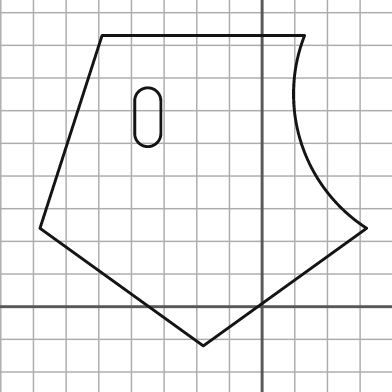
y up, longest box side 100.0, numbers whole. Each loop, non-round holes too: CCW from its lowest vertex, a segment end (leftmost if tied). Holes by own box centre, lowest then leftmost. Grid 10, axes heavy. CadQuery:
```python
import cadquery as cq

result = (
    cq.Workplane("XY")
    .moveTo(-18.0, -12.0)
    .lineTo(32.0, 24.0)
    .threePointArc((12.0, 50.0), (13.0, 83.0))
    .lineTo(-49.0, 83.0)
    .lineTo(-68.0, 24.0)
    .close()
    .moveTo(-39.0, 53.0)
    .threePointArc((-35.0, 49.0), (-31.0, 53.0))
    .lineTo(-31.0, 63.0)
    .threePointArc((-35.0, 67.0), (-39.0, 63.0))
    .close()
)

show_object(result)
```